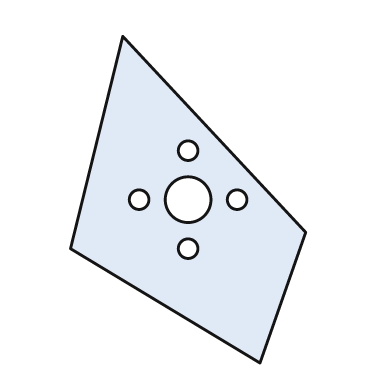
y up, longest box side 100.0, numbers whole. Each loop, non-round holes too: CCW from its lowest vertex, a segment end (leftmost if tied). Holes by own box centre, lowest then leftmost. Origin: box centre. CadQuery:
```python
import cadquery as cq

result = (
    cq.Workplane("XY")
    .moveTo(22.0, -50.0)
    .lineTo(36.0, -10.0)
    .lineTo(-20.0, 50.0)
    .lineTo(-36.0, -15.0)
    .close()
    .moveTo(0.0, -15.0)
    .circle(3.0)
    .moveTo(-15.0, 0.0)
    .circle(3.0)
    .moveTo(0.0, 0.0)
    .circle(7.0)
    .moveTo(15.0, 0.0)
    .circle(3.0)
    .moveTo(0.0, 15.0)
    .circle(3.0)
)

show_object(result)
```